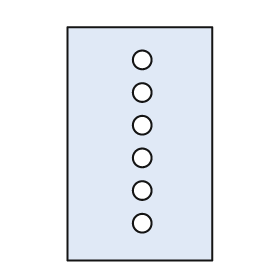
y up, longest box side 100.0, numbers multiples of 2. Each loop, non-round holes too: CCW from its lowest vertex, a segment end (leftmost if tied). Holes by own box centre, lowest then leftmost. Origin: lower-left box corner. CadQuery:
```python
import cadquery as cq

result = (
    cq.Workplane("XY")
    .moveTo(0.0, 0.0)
    .lineTo(62.0, 0.0)
    .lineTo(62.0, 100.0)
    .lineTo(0.0, 100.0)
    .close()
    .moveTo(32.0, 16.0)
    .circle(4.0)
    .moveTo(32.0, 30.0)
    .circle(4.0)
    .moveTo(32.0, 44.0)
    .circle(4.0)
    .moveTo(32.0, 58.0)
    .circle(4.0)
    .moveTo(32.0, 72.0)
    .circle(4.0)
    .moveTo(32.0, 86.0)
    .circle(4.0)
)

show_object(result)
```